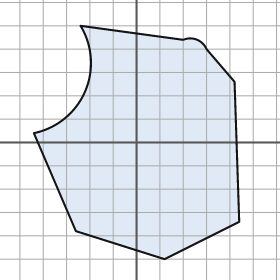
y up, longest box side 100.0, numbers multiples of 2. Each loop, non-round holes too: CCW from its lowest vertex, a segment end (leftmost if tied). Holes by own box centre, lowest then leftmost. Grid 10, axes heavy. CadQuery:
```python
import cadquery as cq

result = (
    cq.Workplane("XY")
    .moveTo(12.0, -50.0)
    .lineTo(44.0, -34.0)
    .lineTo(42.0, 26.0)
    .lineTo(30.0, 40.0)
    .threePointArc((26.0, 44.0), (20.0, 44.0))
    .lineTo(-24.0, 50.0)
    .threePointArc((-22.0, 22.0), (-44.0, 4.0))
    .lineTo(-26.0, -38.0)
    .close()
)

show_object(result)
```